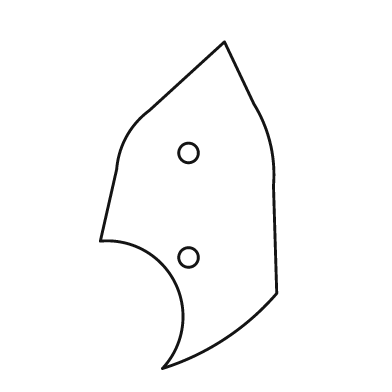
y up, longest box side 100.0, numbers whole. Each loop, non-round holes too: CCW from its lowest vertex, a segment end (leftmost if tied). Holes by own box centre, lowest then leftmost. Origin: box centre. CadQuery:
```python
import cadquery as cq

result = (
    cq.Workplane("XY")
    .moveTo(-8.0, -50.0)
    .threePointArc((11.0, -41.0), (27.0, -27.0))
    .lineTo(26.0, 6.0)
    .threePointArc((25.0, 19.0), (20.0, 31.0))
    .lineTo(11.0, 50.0)
    .lineTo(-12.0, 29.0)
    .threePointArc((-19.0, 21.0), (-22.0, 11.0))
    .lineTo(-27.0, -11.0)
    .threePointArc((-4.0, -24.0), (-8.0, -50.0))
    .close()
    .moveTo(0.0, -16.0)
    .circle(3.0)
    .moveTo(0.0, 16.0)
    .circle(3.0)
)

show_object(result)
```